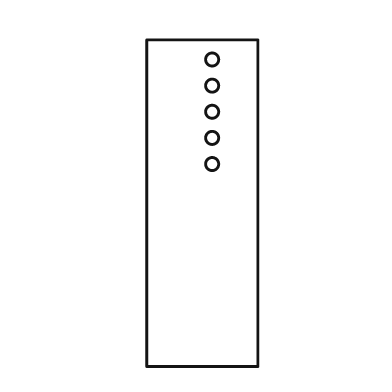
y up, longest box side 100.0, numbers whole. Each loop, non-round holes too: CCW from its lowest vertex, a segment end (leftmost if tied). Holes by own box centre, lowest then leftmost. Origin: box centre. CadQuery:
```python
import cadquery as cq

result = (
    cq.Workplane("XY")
    .moveTo(-17.0, -50.0)
    .lineTo(17.0, -50.0)
    .lineTo(17.0, 50.0)
    .lineTo(-17.0, 50.0)
    .close()
    .moveTo(3.0, 12.0)
    .circle(2.0)
    .moveTo(3.0, 20.0)
    .circle(2.0)
    .moveTo(3.0, 28.0)
    .circle(2.0)
    .moveTo(3.0, 36.0)
    .circle(2.0)
    .moveTo(3.0, 44.0)
    .circle(2.0)
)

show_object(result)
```